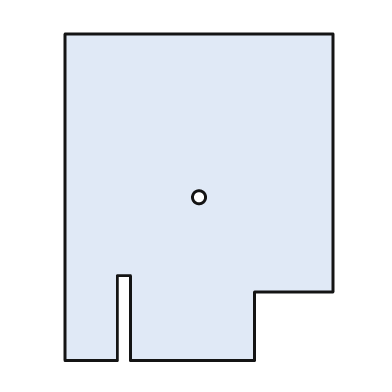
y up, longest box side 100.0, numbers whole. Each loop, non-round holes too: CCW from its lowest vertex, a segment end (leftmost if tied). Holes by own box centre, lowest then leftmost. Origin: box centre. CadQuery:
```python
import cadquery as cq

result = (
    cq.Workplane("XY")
    .moveTo(-41.0, -50.0)
    .lineTo(-25.0, -50.0)
    .lineTo(-25.0, -24.0)
    .lineTo(-21.0, -24.0)
    .lineTo(-21.0, -50.0)
    .lineTo(17.0, -50.0)
    .lineTo(17.0, -29.0)
    .lineTo(41.0, -29.0)
    .lineTo(41.0, 50.0)
    .lineTo(-41.0, 50.0)
    .close()
    .moveTo(0.0, 0.0)
    .circle(2.0)
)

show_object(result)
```